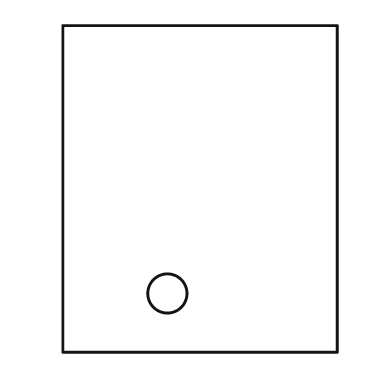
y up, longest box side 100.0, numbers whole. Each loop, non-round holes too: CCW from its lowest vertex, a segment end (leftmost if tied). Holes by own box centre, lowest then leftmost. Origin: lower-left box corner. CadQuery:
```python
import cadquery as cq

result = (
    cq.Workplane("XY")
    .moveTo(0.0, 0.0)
    .lineTo(84.0, 0.0)
    .lineTo(84.0, 100.0)
    .lineTo(0.0, 100.0)
    .close()
    .moveTo(32.0, 18.0)
    .circle(6.0)
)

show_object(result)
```